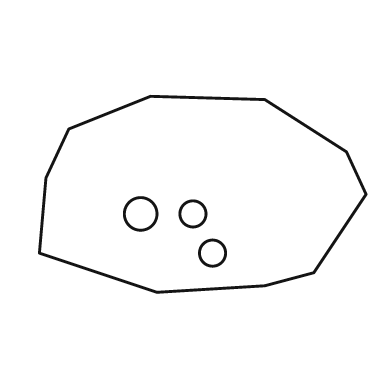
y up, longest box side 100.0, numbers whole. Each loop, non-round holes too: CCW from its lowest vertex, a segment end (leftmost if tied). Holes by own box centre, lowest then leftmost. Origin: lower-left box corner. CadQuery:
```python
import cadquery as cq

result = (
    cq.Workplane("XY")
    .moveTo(36.0, 0.0)
    .lineTo(69.0, 2.0)
    .lineTo(84.0, 6.0)
    .lineTo(100.0, 30.0)
    .lineTo(94.0, 43.0)
    .lineTo(69.0, 59.0)
    .lineTo(34.0, 60.0)
    .lineTo(9.0, 50.0)
    .lineTo(2.0, 35.0)
    .lineTo(0.0, 12.0)
    .close()
    .moveTo(53.0, 12.0)
    .circle(4.0)
    .moveTo(31.0, 24.0)
    .circle(5.0)
    .moveTo(47.0, 24.0)
    .circle(4.0)
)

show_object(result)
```